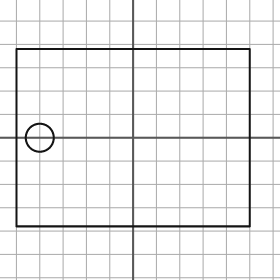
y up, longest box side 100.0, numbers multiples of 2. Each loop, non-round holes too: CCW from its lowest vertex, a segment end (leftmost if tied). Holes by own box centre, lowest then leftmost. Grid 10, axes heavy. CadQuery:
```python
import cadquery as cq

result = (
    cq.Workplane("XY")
    .moveTo(-50.0, -38.0)
    .lineTo(50.0, -38.0)
    .lineTo(50.0, 38.0)
    .lineTo(-50.0, 38.0)
    .close()
    .moveTo(-40.0, 0.0)
    .circle(6.0)
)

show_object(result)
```